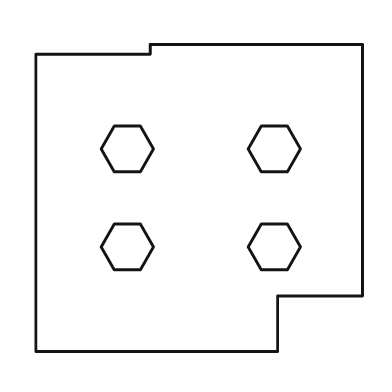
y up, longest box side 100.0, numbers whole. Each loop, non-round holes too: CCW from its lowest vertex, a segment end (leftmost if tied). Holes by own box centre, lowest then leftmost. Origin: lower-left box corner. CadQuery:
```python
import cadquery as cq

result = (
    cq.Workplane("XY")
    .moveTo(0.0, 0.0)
    .lineTo(74.0, 0.0)
    .lineTo(74.0, 17.0)
    .lineTo(100.0, 17.0)
    .lineTo(100.0, 94.0)
    .lineTo(35.0, 94.0)
    .lineTo(35.0, 91.0)
    .lineTo(0.0, 91.0)
    .close()
    .moveTo(24.0, 25.0)
    .lineTo(32.0, 25.0)
    .lineTo(36.0, 32.0)
    .lineTo(32.0, 39.0)
    .lineTo(24.0, 39.0)
    .lineTo(20.0, 32.0)
    .close()
    .moveTo(69.0, 25.0)
    .lineTo(77.0, 25.0)
    .lineTo(81.0, 32.0)
    .lineTo(77.0, 39.0)
    .lineTo(69.0, 39.0)
    .lineTo(65.0, 32.0)
    .close()
    .moveTo(24.0, 55.0)
    .lineTo(32.0, 55.0)
    .lineTo(36.0, 62.0)
    .lineTo(32.0, 69.0)
    .lineTo(24.0, 69.0)
    .lineTo(20.0, 62.0)
    .close()
    .moveTo(69.0, 55.0)
    .lineTo(77.0, 55.0)
    .lineTo(81.0, 62.0)
    .lineTo(77.0, 69.0)
    .lineTo(69.0, 69.0)
    .lineTo(65.0, 62.0)
    .close()
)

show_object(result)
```